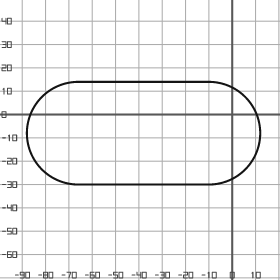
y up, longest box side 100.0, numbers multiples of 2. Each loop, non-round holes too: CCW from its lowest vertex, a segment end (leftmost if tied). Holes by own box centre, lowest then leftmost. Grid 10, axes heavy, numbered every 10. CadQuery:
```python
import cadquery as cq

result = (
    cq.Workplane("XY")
    .moveTo(-66.0, -30.0)
    .lineTo(-10.0, -30.0)
    .threePointArc((12.0, -8.0), (-10.0, 14.0))
    .lineTo(-66.0, 14.0)
    .threePointArc((-88.0, -8.0), (-66.0, -30.0))
    .close()
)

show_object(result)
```